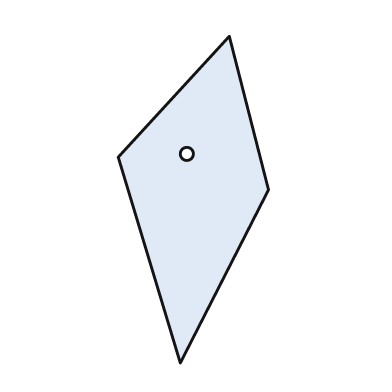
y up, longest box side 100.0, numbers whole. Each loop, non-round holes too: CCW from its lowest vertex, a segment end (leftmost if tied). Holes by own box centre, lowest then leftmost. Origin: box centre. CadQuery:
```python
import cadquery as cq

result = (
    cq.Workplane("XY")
    .moveTo(-4.0, -50.0)
    .lineTo(23.0, 3.0)
    .lineTo(11.0, 50.0)
    .lineTo(-23.0, 13.0)
    .close()
    .moveTo(-2.0, 14.0)
    .circle(2.0)
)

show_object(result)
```